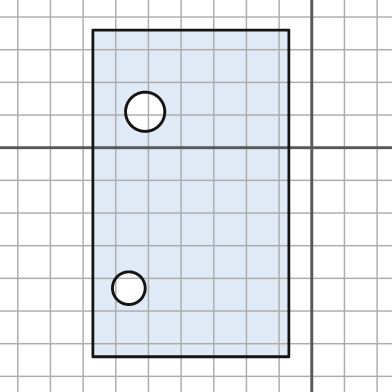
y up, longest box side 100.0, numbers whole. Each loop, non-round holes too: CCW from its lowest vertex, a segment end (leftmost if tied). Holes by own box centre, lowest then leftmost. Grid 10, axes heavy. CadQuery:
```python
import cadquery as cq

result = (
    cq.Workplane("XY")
    .moveTo(-67.0, -64.0)
    .lineTo(-7.0, -64.0)
    .lineTo(-7.0, 36.0)
    .lineTo(-67.0, 36.0)
    .close()
    .moveTo(-56.0, -43.0)
    .circle(5.0)
    .moveTo(-51.0, 11.0)
    .circle(6.0)
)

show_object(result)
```